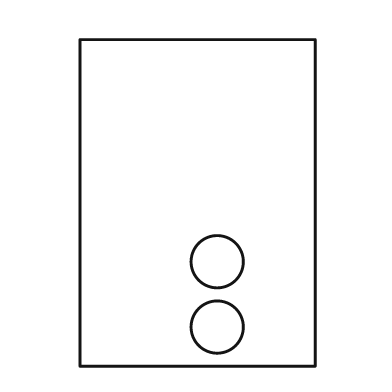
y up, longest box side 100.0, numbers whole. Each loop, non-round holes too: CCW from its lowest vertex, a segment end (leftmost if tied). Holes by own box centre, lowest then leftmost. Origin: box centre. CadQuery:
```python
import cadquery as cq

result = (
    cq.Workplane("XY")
    .moveTo(-36.0, -50.0)
    .lineTo(36.0, -50.0)
    .lineTo(36.0, 50.0)
    .lineTo(-36.0, 50.0)
    .close()
    .moveTo(6.0, -38.0)
    .circle(8.0)
    .moveTo(6.0, -18.0)
    .circle(8.0)
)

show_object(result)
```